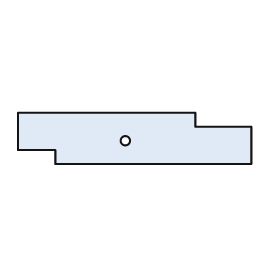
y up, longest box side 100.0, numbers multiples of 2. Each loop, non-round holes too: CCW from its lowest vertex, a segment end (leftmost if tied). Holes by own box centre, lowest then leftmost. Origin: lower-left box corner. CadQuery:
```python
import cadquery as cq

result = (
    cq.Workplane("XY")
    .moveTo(16.0, 0.0)
    .lineTo(100.0, 0.0)
    .lineTo(100.0, 16.0)
    .lineTo(76.0, 16.0)
    .lineTo(76.0, 22.0)
    .lineTo(0.0, 22.0)
    .lineTo(0.0, 6.0)
    .lineTo(16.0, 6.0)
    .close()
    .moveTo(46.0, 10.0)
    .circle(2.0)
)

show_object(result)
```